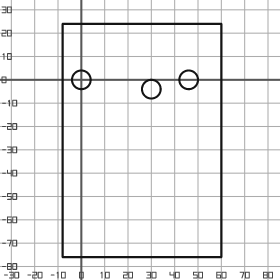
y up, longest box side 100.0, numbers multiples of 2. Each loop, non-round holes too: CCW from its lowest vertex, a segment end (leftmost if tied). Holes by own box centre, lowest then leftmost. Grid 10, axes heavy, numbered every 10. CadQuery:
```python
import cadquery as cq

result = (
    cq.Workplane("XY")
    .moveTo(-8.0, -76.0)
    .lineTo(60.0, -76.0)
    .lineTo(60.0, 24.0)
    .lineTo(-8.0, 24.0)
    .close()
    .moveTo(30.0, -4.0)
    .circle(4.0)
    .moveTo(0.0, 0.0)
    .circle(4.0)
    .moveTo(46.0, 0.0)
    .circle(4.0)
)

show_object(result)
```